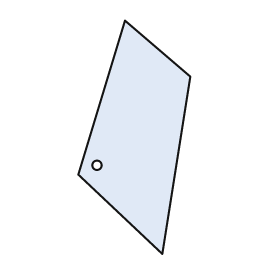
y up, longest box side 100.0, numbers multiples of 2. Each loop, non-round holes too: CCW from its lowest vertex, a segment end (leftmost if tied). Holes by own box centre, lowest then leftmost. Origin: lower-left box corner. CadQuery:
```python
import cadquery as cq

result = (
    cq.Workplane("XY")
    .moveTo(36.0, 0.0)
    .lineTo(48.0, 76.0)
    .lineTo(20.0, 100.0)
    .lineTo(0.0, 34.0)
    .close()
    .moveTo(8.0, 38.0)
    .circle(2.0)
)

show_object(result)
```